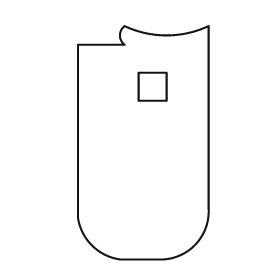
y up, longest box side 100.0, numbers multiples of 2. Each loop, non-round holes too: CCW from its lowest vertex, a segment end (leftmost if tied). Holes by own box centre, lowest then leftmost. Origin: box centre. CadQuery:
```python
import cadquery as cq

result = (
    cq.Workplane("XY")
    .moveTo(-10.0, -50.0)
    .lineTo(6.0, -50.0)
    .threePointArc((22.0, -44.0), (28.0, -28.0))
    .lineTo(28.0, 50.0)
    .threePointArc((10.0, 46.0), (-8.0, 50.0))
    .threePointArc((-10.0, 46.0), (-8.0, 42.0))
    .lineTo(-28.0, 42.0)
    .lineTo(-28.0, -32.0)
    .threePointArc((-22.0, -44.0), (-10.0, -50.0))
    .close()
    .moveTo(-2.0, 18.0)
    .lineTo(10.0, 18.0)
    .lineTo(10.0, 30.0)
    .lineTo(-2.0, 30.0)
    .close()
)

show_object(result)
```